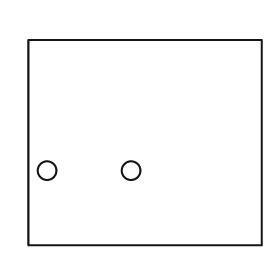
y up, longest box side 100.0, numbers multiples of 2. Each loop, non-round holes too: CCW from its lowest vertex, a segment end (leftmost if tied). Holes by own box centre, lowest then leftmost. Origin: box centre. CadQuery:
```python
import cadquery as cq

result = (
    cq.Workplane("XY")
    .moveTo(-50.0, -44.0)
    .lineTo(50.0, -44.0)
    .lineTo(50.0, 44.0)
    .lineTo(-50.0, 44.0)
    .close()
    .moveTo(-42.0, -12.0)
    .circle(4.0)
    .moveTo(-6.0, -12.0)
    .circle(4.0)
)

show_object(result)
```